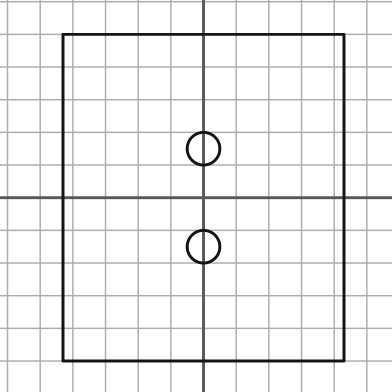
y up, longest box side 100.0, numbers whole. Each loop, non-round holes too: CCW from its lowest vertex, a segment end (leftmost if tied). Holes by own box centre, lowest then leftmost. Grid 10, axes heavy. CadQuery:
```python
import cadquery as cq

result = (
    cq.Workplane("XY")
    .moveTo(-43.0, -50.0)
    .lineTo(43.0, -50.0)
    .lineTo(43.0, 50.0)
    .lineTo(-43.0, 50.0)
    .close()
    .moveTo(0.0, -15.0)
    .circle(5.0)
    .moveTo(0.0, 15.0)
    .circle(5.0)
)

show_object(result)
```